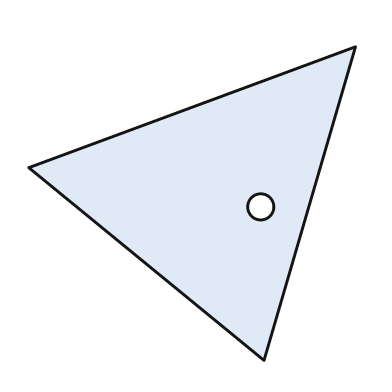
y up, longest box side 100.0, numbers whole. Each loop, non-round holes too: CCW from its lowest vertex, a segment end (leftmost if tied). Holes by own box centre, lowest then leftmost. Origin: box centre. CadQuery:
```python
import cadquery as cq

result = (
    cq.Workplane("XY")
    .moveTo(22.0, -48.0)
    .lineTo(50.0, 48.0)
    .lineTo(-50.0, 11.0)
    .close()
    .moveTo(21.0, -1.0)
    .circle(4.0)
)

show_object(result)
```